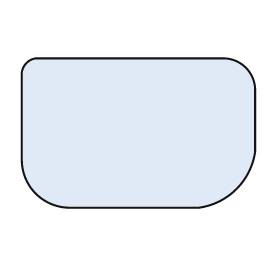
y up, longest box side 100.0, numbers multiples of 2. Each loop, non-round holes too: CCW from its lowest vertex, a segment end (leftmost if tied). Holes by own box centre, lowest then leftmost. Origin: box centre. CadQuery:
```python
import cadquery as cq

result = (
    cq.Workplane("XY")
    .moveTo(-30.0, -32.0)
    .lineTo(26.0, -32.0)
    .threePointArc((42.0, -24.0), (50.0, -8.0))
    .lineTo(50.0, 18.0)
    .threePointArc((46.0, 28.0), (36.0, 32.0))
    .lineTo(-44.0, 32.0)
    .threePointArc((-48.0, 30.0), (-50.0, 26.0))
    .lineTo(-50.0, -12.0)
    .threePointArc((-44.0, -26.0), (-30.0, -32.0))
    .close()
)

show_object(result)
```